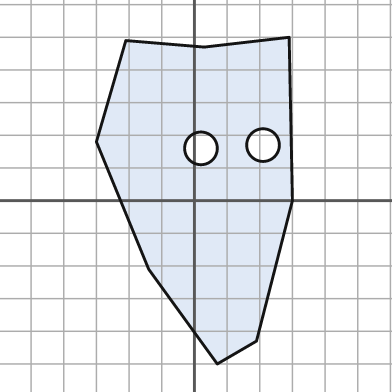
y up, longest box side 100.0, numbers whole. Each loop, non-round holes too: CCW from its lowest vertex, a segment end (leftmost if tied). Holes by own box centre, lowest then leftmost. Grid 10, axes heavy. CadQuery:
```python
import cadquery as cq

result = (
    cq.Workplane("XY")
    .moveTo(7.0, -50.0)
    .lineTo(19.0, -43.0)
    .lineTo(30.0, 0.0)
    .lineTo(29.0, 50.0)
    .lineTo(3.0, 47.0)
    .lineTo(-21.0, 49.0)
    .lineTo(-30.0, 18.0)
    .lineTo(-14.0, -21.0)
    .close()
    .moveTo(2.0, 16.0)
    .circle(5.0)
    .moveTo(21.0, 17.0)
    .circle(5.0)
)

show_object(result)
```